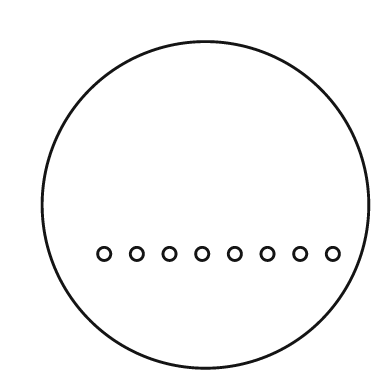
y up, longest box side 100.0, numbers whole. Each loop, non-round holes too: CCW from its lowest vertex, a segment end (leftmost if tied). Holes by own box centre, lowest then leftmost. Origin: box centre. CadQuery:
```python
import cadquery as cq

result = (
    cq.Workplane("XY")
    .moveTo(0.0, 0.0)
    .circle(50.0)
    .moveTo(-31.0, -15.0)
    .circle(2.0)
    .moveTo(-21.0, -15.0)
    .circle(2.0)
    .moveTo(-11.0, -15.0)
    .circle(2.0)
    .moveTo(-1.0, -15.0)
    .circle(2.0)
    .moveTo(9.0, -15.0)
    .circle(2.0)
    .moveTo(19.0, -15.0)
    .circle(2.0)
    .moveTo(29.0, -15.0)
    .circle(2.0)
    .moveTo(39.0, -15.0)
    .circle(2.0)
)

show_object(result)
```